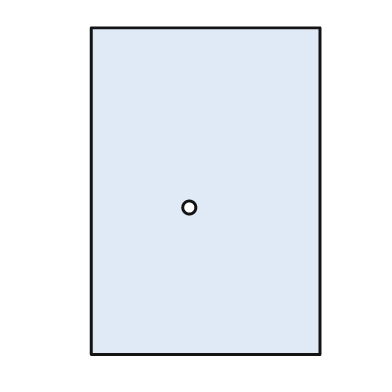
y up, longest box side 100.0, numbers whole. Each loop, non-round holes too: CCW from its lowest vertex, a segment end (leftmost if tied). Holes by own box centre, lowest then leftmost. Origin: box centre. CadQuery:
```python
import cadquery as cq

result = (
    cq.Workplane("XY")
    .moveTo(-35.0, -50.0)
    .lineTo(35.0, -50.0)
    .lineTo(35.0, 50.0)
    .lineTo(-35.0, 50.0)
    .close()
    .moveTo(-5.0, -5.0)
    .circle(2.0)
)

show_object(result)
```